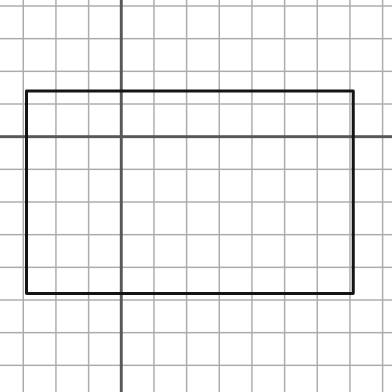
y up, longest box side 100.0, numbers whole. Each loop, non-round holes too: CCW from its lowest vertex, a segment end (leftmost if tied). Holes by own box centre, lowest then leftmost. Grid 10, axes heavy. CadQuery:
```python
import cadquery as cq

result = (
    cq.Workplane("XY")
    .moveTo(-29.0, -48.0)
    .lineTo(71.0, -48.0)
    .lineTo(71.0, 14.0)
    .lineTo(-29.0, 14.0)
    .close()
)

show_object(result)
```